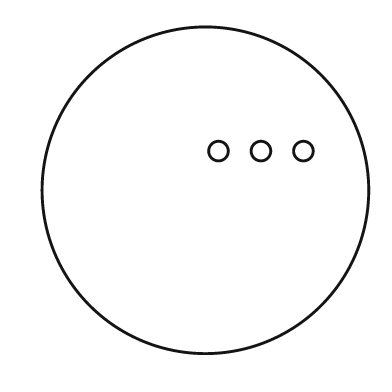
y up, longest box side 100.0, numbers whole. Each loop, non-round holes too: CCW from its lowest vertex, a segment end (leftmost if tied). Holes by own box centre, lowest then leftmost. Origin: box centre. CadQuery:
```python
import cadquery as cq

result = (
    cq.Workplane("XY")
    .moveTo(0.0, 0.0)
    .circle(50.0)
    .moveTo(4.0, 12.0)
    .circle(3.0)
    .moveTo(17.0, 12.0)
    .circle(3.0)
    .moveTo(30.0, 12.0)
    .circle(3.0)
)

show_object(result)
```